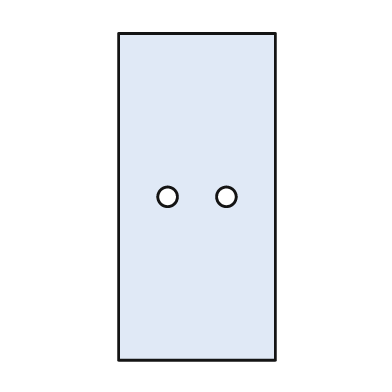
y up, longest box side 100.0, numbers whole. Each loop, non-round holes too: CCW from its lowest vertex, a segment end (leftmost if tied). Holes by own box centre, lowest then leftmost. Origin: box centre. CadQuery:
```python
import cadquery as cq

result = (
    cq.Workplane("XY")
    .moveTo(-24.0, -50.0)
    .lineTo(24.0, -50.0)
    .lineTo(24.0, 50.0)
    .lineTo(-24.0, 50.0)
    .close()
    .moveTo(-9.0, 0.0)
    .circle(3.0)
    .moveTo(9.0, 0.0)
    .circle(3.0)
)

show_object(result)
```